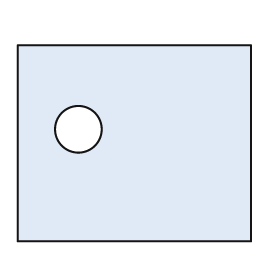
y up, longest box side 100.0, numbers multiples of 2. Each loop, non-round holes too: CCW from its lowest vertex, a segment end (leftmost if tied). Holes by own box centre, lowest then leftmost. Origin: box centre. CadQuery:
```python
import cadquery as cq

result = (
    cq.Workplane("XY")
    .moveTo(-50.0, -42.0)
    .lineTo(50.0, -42.0)
    .lineTo(50.0, 42.0)
    .lineTo(-50.0, 42.0)
    .close()
    .moveTo(-24.0, 6.0)
    .circle(10.0)
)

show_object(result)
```